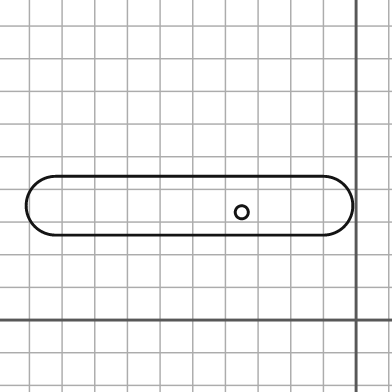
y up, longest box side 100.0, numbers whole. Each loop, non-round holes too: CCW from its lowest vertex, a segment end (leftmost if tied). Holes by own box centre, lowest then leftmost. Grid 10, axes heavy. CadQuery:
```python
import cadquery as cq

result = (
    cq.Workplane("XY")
    .moveTo(-92.0, 26.0)
    .lineTo(-10.0, 26.0)
    .threePointArc((-1.0, 35.0), (-10.0, 44.0))
    .lineTo(-92.0, 44.0)
    .threePointArc((-101.0, 35.0), (-92.0, 26.0))
    .close()
    .moveTo(-35.0, 33.0)
    .circle(2.0)
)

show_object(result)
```